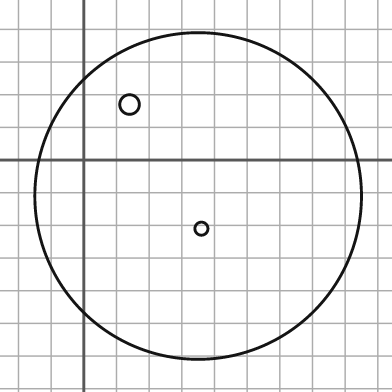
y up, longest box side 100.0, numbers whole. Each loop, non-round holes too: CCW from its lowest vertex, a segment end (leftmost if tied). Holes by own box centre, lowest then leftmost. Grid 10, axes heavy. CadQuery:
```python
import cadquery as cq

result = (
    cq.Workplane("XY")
    .moveTo(35.0, -11.0)
    .circle(50.0)
    .moveTo(36.0, -21.0)
    .circle(2.0)
    .moveTo(14.0, 17.0)
    .circle(3.0)
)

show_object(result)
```